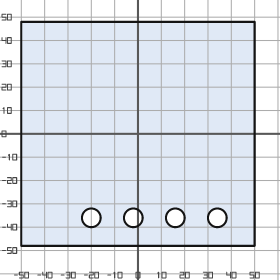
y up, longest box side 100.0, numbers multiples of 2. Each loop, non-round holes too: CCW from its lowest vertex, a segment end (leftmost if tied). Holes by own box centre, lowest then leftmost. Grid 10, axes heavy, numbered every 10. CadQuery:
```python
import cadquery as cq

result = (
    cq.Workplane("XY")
    .moveTo(-50.0, -48.0)
    .lineTo(50.0, -48.0)
    .lineTo(50.0, 48.0)
    .lineTo(-50.0, 48.0)
    .close()
    .moveTo(-20.0, -36.0)
    .circle(4.0)
    .moveTo(-2.0, -36.0)
    .circle(4.0)
    .moveTo(16.0, -36.0)
    .circle(4.0)
    .moveTo(34.0, -36.0)
    .circle(4.0)
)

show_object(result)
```